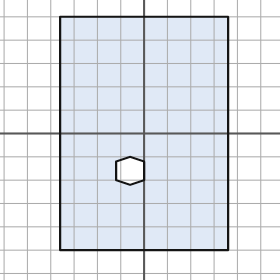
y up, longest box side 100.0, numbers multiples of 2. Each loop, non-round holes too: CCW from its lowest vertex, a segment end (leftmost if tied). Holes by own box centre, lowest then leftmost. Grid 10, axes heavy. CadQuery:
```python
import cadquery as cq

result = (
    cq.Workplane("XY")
    .moveTo(-36.0, -50.0)
    .lineTo(36.0, -50.0)
    .lineTo(36.0, 50.0)
    .lineTo(-36.0, 50.0)
    .close()
    .moveTo(-6.0, -22.0)
    .lineTo(0.0, -20.0)
    .lineTo(0.0, -12.0)
    .lineTo(-6.0, -10.0)
    .lineTo(-12.0, -12.0)
    .lineTo(-12.0, -20.0)
    .close()
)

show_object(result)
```